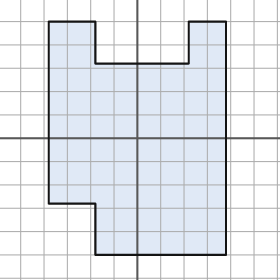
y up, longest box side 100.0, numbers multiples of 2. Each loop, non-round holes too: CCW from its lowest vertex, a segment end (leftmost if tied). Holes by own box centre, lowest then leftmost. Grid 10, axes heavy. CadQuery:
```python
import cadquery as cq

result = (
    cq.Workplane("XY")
    .moveTo(-18.0, -50.0)
    .lineTo(38.0, -50.0)
    .lineTo(38.0, 50.0)
    .lineTo(22.0, 50.0)
    .lineTo(22.0, 32.0)
    .lineTo(-18.0, 32.0)
    .lineTo(-18.0, 50.0)
    .lineTo(-38.0, 50.0)
    .lineTo(-38.0, -28.0)
    .lineTo(-18.0, -28.0)
    .close()
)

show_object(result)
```